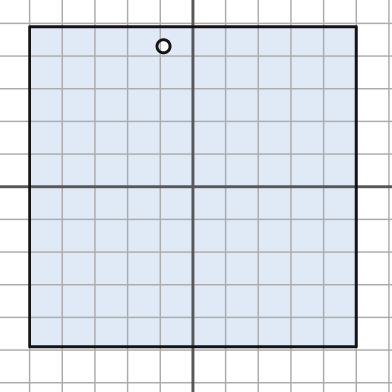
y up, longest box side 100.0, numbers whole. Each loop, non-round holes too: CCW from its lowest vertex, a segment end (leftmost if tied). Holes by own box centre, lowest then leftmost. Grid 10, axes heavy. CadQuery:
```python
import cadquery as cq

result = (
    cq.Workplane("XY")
    .moveTo(-50.0, -49.0)
    .lineTo(50.0, -49.0)
    .lineTo(50.0, 49.0)
    .lineTo(-50.0, 49.0)
    .close()
    .moveTo(-9.0, 43.0)
    .circle(2.0)
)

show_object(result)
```